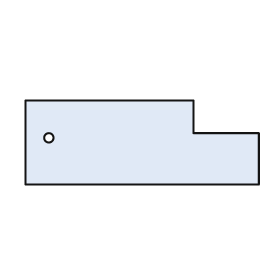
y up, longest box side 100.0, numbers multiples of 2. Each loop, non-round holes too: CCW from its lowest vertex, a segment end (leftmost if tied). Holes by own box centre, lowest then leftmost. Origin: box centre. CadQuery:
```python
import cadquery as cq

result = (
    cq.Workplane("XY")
    .moveTo(-50.0, -18.0)
    .lineTo(50.0, -18.0)
    .lineTo(50.0, 4.0)
    .lineTo(22.0, 4.0)
    .lineTo(22.0, 18.0)
    .lineTo(-50.0, 18.0)
    .close()
    .moveTo(-40.0, 2.0)
    .circle(2.0)
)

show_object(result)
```